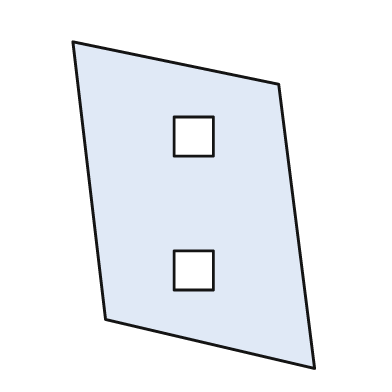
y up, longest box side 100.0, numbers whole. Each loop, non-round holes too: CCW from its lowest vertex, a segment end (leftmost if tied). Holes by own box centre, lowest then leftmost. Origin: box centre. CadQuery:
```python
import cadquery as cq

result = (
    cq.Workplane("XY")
    .moveTo(37.0, -50.0)
    .lineTo(26.0, 37.0)
    .lineTo(-37.0, 50.0)
    .lineTo(-27.0, -35.0)
    .close()
    .moveTo(-6.0, -26.0)
    .lineTo(6.0, -26.0)
    .lineTo(6.0, -14.0)
    .lineTo(-6.0, -14.0)
    .close()
    .moveTo(-6.0, 15.0)
    .lineTo(6.0, 15.0)
    .lineTo(6.0, 27.0)
    .lineTo(-6.0, 27.0)
    .close()
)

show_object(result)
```